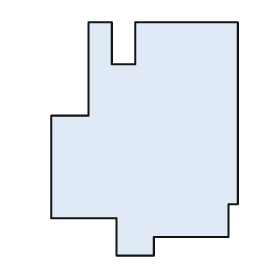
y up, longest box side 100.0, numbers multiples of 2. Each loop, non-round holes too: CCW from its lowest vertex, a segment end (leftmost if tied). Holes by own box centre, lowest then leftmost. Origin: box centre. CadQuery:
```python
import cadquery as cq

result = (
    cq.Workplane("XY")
    .moveTo(-12.0, -50.0)
    .lineTo(4.0, -50.0)
    .lineTo(4.0, -42.0)
    .lineTo(36.0, -42.0)
    .lineTo(36.0, -28.0)
    .lineTo(40.0, -28.0)
    .lineTo(40.0, 50.0)
    .lineTo(-4.0, 50.0)
    .lineTo(-4.0, 32.0)
    .lineTo(-14.0, 32.0)
    .lineTo(-14.0, 50.0)
    .lineTo(-24.0, 50.0)
    .lineTo(-24.0, 10.0)
    .lineTo(-40.0, 10.0)
    .lineTo(-40.0, -34.0)
    .lineTo(-12.0, -34.0)
    .close()
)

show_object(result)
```